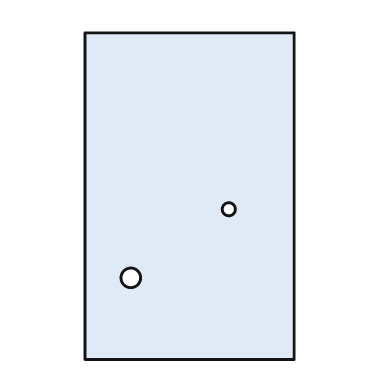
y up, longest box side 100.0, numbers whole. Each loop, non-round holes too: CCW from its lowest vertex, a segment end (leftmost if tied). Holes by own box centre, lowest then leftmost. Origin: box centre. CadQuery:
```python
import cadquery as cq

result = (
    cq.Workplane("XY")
    .moveTo(-32.0, -50.0)
    .lineTo(32.0, -50.0)
    .lineTo(32.0, 50.0)
    .lineTo(-32.0, 50.0)
    .close()
    .moveTo(-18.0, -25.0)
    .circle(3.0)
    .moveTo(12.0, -4.0)
    .circle(2.0)
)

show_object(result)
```